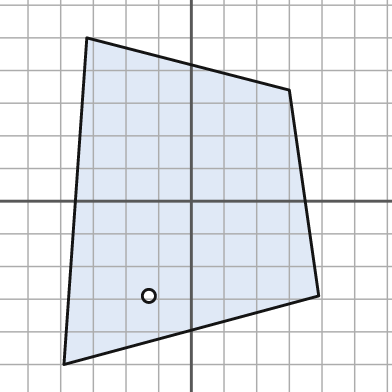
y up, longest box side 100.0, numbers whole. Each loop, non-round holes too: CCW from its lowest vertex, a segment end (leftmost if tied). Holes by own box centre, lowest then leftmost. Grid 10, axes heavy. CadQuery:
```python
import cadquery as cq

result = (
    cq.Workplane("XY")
    .moveTo(-39.0, -50.0)
    .lineTo(39.0, -29.0)
    .lineTo(30.0, 34.0)
    .lineTo(-32.0, 50.0)
    .close()
    .moveTo(-13.0, -29.0)
    .circle(2.0)
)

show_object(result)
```